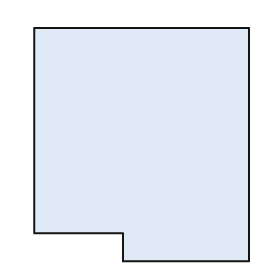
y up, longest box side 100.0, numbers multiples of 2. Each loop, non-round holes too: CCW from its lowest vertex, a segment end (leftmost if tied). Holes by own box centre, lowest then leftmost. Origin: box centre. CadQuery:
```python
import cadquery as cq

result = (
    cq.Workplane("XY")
    .moveTo(-8.0, -50.0)
    .lineTo(46.0, -50.0)
    .lineTo(46.0, 50.0)
    .lineTo(-46.0, 50.0)
    .lineTo(-46.0, -38.0)
    .lineTo(-8.0, -38.0)
    .close()
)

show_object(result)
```